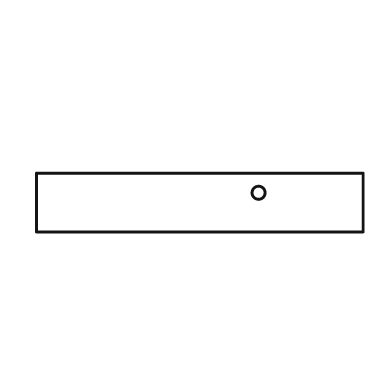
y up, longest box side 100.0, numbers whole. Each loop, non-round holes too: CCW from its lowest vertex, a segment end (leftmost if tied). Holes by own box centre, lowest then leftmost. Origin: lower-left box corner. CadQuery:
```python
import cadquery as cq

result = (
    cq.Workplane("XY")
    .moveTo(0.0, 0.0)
    .lineTo(100.0, 0.0)
    .lineTo(100.0, 18.0)
    .lineTo(0.0, 18.0)
    .close()
    .moveTo(68.0, 12.0)
    .circle(2.0)
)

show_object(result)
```